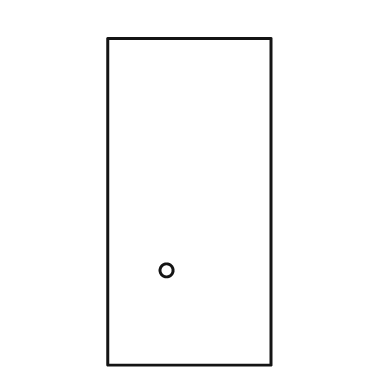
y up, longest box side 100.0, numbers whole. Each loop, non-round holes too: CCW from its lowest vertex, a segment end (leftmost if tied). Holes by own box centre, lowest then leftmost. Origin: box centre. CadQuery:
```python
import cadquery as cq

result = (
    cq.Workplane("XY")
    .moveTo(-25.0, -50.0)
    .lineTo(25.0, -50.0)
    .lineTo(25.0, 50.0)
    .lineTo(-25.0, 50.0)
    .close()
    .moveTo(-7.0, -21.0)
    .circle(2.0)
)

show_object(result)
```